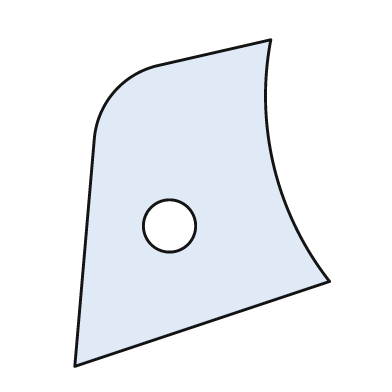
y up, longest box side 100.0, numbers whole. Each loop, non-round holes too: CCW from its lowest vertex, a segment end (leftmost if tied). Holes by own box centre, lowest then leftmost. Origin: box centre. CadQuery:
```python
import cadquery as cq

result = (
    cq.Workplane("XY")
    .moveTo(-39.0, -50.0)
    .lineTo(39.0, -24.0)
    .threePointArc((22.0, 11.0), (21.0, 50.0))
    .lineTo(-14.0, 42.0)
    .threePointArc((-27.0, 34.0), (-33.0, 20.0))
    .close()
    .moveTo(-10.0, -7.0)
    .circle(8.0)
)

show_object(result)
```